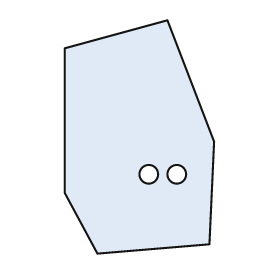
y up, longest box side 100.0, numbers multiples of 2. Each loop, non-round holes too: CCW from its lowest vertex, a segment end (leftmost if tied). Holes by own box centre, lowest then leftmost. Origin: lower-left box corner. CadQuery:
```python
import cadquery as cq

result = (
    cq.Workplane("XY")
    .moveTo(14.0, 0.0)
    .lineTo(62.0, 4.0)
    .lineTo(64.0, 48.0)
    .lineTo(44.0, 100.0)
    .lineTo(0.0, 88.0)
    .lineTo(0.0, 26.0)
    .close()
    .moveTo(36.0, 34.0)
    .circle(4.0)
    .moveTo(48.0, 34.0)
    .circle(4.0)
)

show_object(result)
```